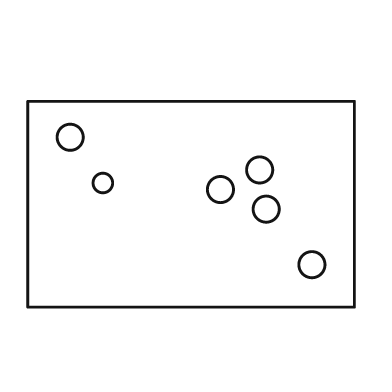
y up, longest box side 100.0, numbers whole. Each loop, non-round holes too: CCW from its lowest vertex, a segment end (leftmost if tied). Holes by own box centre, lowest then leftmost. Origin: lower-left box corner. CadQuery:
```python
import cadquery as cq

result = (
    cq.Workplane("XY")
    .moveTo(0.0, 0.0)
    .lineTo(100.0, 0.0)
    .lineTo(100.0, 63.0)
    .lineTo(0.0, 63.0)
    .close()
    .moveTo(87.0, 13.0)
    .circle(4.0)
    .moveTo(73.0, 30.0)
    .circle(4.0)
    .moveTo(59.0, 36.0)
    .circle(4.0)
    .moveTo(23.0, 38.0)
    .circle(3.0)
    .moveTo(71.0, 42.0)
    .circle(4.0)
    .moveTo(13.0, 52.0)
    .circle(4.0)
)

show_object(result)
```